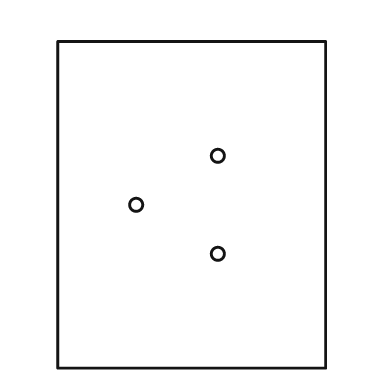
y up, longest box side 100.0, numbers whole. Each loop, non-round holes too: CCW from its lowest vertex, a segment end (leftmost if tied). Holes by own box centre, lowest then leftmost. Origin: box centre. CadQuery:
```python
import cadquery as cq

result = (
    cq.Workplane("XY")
    .moveTo(-41.0, -50.0)
    .lineTo(41.0, -50.0)
    .lineTo(41.0, 50.0)
    .lineTo(-41.0, 50.0)
    .close()
    .moveTo(8.0, -15.0)
    .circle(2.0)
    .moveTo(-17.0, 0.0)
    .circle(2.0)
    .moveTo(8.0, 15.0)
    .circle(2.0)
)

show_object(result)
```